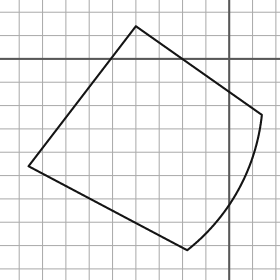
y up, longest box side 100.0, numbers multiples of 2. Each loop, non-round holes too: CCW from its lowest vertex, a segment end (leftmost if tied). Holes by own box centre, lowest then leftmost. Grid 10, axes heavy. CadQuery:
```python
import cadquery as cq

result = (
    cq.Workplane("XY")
    .moveTo(-18.0, -82.0)
    .threePointArc((4.0, -56.0), (14.0, -24.0))
    .lineTo(-40.0, 14.0)
    .lineTo(-86.0, -46.0)
    .close()
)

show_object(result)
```